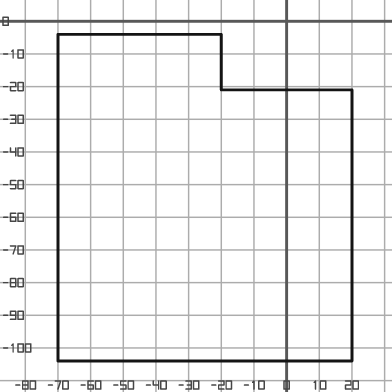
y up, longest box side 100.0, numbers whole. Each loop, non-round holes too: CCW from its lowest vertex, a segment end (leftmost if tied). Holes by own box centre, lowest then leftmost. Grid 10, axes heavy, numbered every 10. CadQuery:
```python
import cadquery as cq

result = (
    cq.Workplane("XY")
    .moveTo(-70.0, -104.0)
    .lineTo(20.0, -104.0)
    .lineTo(20.0, -21.0)
    .lineTo(-20.0, -21.0)
    .lineTo(-20.0, -4.0)
    .lineTo(-70.0, -4.0)
    .close()
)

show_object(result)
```